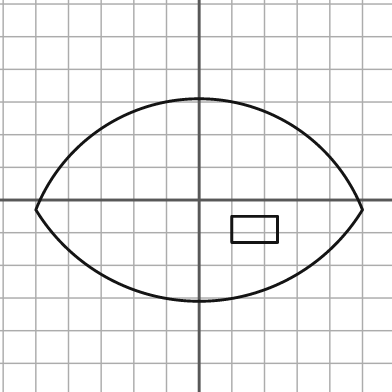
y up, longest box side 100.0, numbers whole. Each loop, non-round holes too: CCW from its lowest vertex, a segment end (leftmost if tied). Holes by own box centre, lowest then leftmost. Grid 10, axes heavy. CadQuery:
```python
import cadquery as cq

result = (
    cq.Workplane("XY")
    .moveTo(-50.0, -3.0)
    .threePointArc((0.0, -31.0), (50.0, -3.0))
    .threePointArc((0.0, 31.0), (-50.0, -3.0))
    .close()
    .moveTo(10.0, -13.0)
    .lineTo(24.0, -13.0)
    .lineTo(24.0, -5.0)
    .lineTo(10.0, -5.0)
    .close()
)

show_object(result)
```